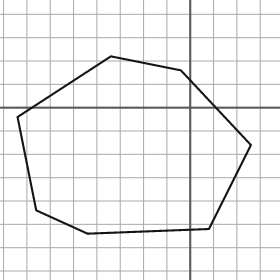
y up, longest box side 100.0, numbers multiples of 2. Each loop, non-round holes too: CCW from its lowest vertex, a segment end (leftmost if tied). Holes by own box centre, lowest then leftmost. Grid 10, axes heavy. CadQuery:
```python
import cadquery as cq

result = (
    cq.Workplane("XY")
    .moveTo(-44.0, -54.0)
    .lineTo(8.0, -52.0)
    .lineTo(26.0, -16.0)
    .lineTo(-4.0, 16.0)
    .lineTo(-34.0, 22.0)
    .lineTo(-74.0, -4.0)
    .lineTo(-66.0, -44.0)
    .close()
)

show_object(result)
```